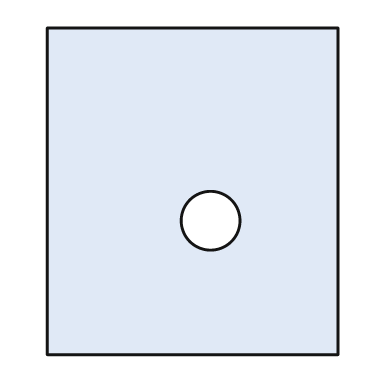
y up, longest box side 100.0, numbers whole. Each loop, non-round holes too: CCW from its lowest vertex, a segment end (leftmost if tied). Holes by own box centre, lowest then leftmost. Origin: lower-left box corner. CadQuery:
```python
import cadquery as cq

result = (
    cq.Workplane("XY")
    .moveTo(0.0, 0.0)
    .lineTo(89.0, 0.0)
    .lineTo(89.0, 100.0)
    .lineTo(0.0, 100.0)
    .close()
    .moveTo(50.0, 41.0)
    .circle(9.0)
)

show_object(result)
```